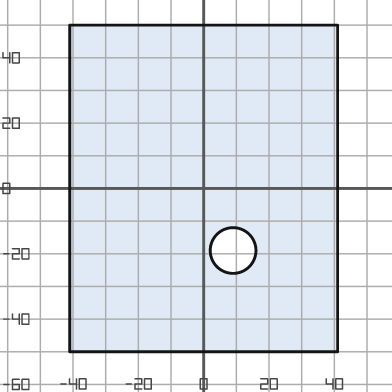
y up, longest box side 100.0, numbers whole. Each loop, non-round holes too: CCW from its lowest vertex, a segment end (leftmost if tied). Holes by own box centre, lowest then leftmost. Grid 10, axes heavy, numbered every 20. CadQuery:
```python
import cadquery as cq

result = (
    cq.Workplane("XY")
    .moveTo(-41.0, -50.0)
    .lineTo(41.0, -50.0)
    .lineTo(41.0, 50.0)
    .lineTo(-41.0, 50.0)
    .close()
    .moveTo(9.0, -19.0)
    .circle(7.0)
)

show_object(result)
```